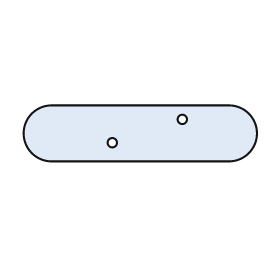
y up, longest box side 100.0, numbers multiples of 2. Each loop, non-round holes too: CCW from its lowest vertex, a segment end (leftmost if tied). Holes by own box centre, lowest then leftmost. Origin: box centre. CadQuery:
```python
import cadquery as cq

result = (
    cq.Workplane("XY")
    .moveTo(-38.0, -12.0)
    .lineTo(38.0, -12.0)
    .threePointArc((50.0, 0.0), (38.0, 12.0))
    .lineTo(-38.0, 12.0)
    .threePointArc((-50.0, 0.0), (-38.0, -12.0))
    .close()
    .moveTo(-12.0, -4.0)
    .circle(2.0)
    .moveTo(18.0, 6.0)
    .circle(2.0)
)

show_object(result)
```